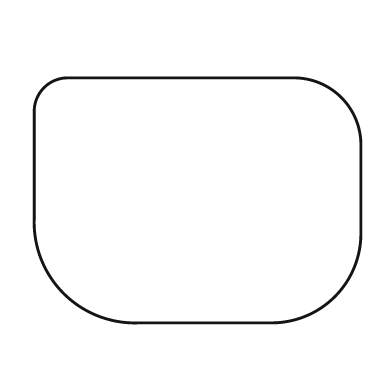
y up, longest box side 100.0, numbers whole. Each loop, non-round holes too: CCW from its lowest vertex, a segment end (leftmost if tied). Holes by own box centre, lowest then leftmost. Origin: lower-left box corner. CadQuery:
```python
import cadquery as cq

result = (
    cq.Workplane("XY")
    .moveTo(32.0, 0.0)
    .lineTo(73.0, 0.0)
    .threePointArc((92.0, 8.0), (100.0, 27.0))
    .lineTo(100.0, 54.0)
    .threePointArc((94.0, 69.0), (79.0, 75.0))
    .lineTo(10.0, 75.0)
    .threePointArc((3.0, 72.0), (0.0, 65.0))
    .lineTo(0.0, 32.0)
    .threePointArc((9.0, 9.0), (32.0, 0.0))
    .close()
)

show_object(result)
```